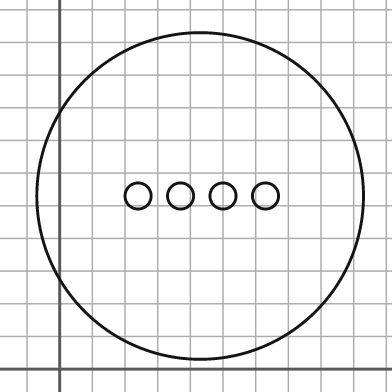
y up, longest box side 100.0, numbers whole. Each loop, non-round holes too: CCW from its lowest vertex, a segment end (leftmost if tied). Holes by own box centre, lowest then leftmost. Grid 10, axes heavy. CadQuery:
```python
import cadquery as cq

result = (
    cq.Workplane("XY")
    .moveTo(43.0, 53.0)
    .circle(50.0)
    .moveTo(24.0, 53.0)
    .circle(4.0)
    .moveTo(37.0, 53.0)
    .circle(4.0)
    .moveTo(50.0, 53.0)
    .circle(4.0)
    .moveTo(63.0, 53.0)
    .circle(4.0)
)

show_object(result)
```